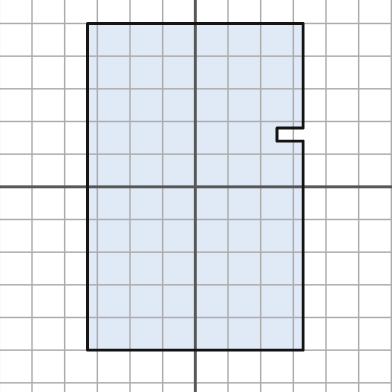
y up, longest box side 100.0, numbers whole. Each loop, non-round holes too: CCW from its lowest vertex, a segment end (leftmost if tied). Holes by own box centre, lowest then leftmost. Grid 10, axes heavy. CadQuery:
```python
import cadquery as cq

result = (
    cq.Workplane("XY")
    .moveTo(-33.0, -50.0)
    .lineTo(33.0, -50.0)
    .lineTo(33.0, 14.0)
    .lineTo(25.0, 14.0)
    .lineTo(25.0, 18.0)
    .lineTo(33.0, 18.0)
    .lineTo(33.0, 50.0)
    .lineTo(-33.0, 50.0)
    .close()
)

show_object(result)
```